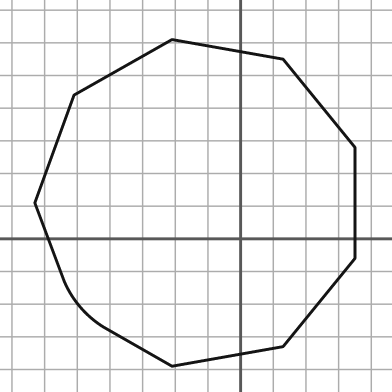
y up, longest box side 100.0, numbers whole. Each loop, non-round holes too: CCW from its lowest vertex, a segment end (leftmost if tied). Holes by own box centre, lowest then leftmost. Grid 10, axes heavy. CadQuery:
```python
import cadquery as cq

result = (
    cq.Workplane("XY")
    .moveTo(-21.0, -39.0)
    .lineTo(13.0, -33.0)
    .lineTo(35.0, -6.0)
    .lineTo(35.0, 28.0)
    .lineTo(13.0, 55.0)
    .lineTo(-21.0, 61.0)
    .lineTo(-51.0, 44.0)
    .lineTo(-63.0, 11.0)
    .lineTo(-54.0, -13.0)
    .threePointArc((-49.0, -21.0), (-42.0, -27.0))
    .close()
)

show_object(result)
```